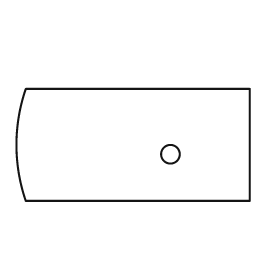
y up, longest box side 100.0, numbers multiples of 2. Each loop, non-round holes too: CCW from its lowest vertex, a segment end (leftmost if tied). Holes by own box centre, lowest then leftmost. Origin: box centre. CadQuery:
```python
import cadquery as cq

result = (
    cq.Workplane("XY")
    .moveTo(-46.0, -24.0)
    .lineTo(50.0, -24.0)
    .lineTo(50.0, 24.0)
    .lineTo(-46.0, 24.0)
    .threePointArc((-50.0, 0.0), (-46.0, -24.0))
    .close()
    .moveTo(16.0, -4.0)
    .circle(4.0)
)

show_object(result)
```